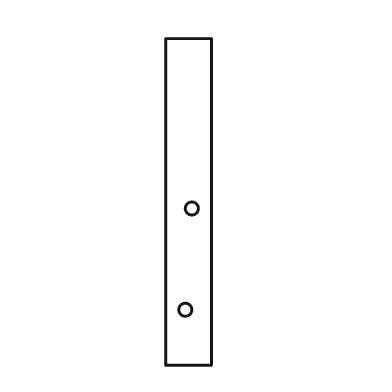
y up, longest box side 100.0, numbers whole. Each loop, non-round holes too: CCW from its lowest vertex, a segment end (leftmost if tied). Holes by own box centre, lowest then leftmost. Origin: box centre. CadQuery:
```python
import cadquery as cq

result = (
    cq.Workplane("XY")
    .moveTo(-7.0, -50.0)
    .lineTo(7.0, -50.0)
    .lineTo(7.0, 50.0)
    .lineTo(-7.0, 50.0)
    .close()
    .moveTo(-1.0, -33.0)
    .circle(2.0)
    .moveTo(1.0, -2.0)
    .circle(2.0)
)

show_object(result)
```